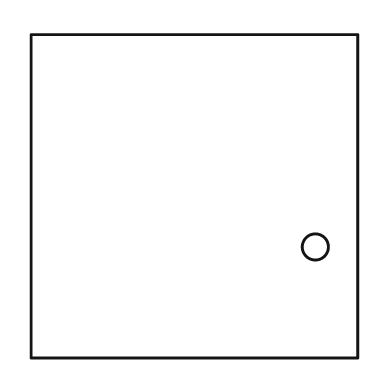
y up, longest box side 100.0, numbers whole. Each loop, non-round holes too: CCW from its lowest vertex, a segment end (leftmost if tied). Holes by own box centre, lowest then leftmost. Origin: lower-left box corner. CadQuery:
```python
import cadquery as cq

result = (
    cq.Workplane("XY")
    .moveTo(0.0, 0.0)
    .lineTo(100.0, 0.0)
    .lineTo(100.0, 99.0)
    .lineTo(0.0, 99.0)
    .close()
    .moveTo(87.0, 34.0)
    .circle(4.0)
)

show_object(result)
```